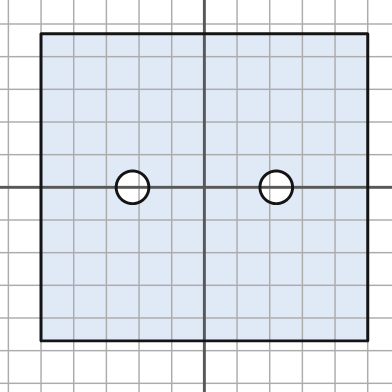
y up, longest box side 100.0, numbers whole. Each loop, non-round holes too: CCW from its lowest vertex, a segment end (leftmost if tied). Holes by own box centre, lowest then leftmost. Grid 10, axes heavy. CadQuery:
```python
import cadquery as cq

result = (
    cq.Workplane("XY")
    .moveTo(-50.0, -47.0)
    .lineTo(50.0, -47.0)
    .lineTo(50.0, 47.0)
    .lineTo(-50.0, 47.0)
    .close()
    .moveTo(-22.0, 0.0)
    .circle(5.0)
    .moveTo(22.0, 0.0)
    .circle(5.0)
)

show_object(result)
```